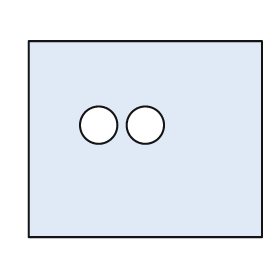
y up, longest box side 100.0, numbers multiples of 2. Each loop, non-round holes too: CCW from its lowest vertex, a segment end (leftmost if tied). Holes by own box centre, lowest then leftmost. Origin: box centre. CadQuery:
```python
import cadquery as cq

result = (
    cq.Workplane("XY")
    .moveTo(-50.0, -42.0)
    .lineTo(50.0, -42.0)
    .lineTo(50.0, 42.0)
    .lineTo(-50.0, 42.0)
    .close()
    .moveTo(-20.0, 6.0)
    .circle(8.0)
    .moveTo(0.0, 6.0)
    .circle(8.0)
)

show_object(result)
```